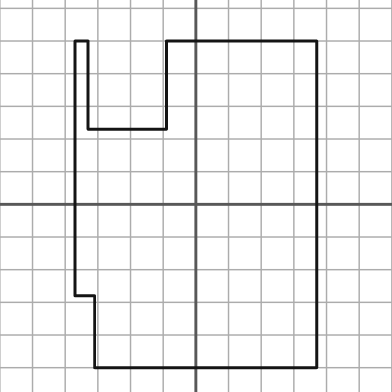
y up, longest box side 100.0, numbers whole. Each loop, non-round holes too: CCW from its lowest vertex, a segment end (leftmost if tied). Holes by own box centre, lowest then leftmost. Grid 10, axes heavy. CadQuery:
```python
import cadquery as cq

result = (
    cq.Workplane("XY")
    .moveTo(-31.0, -50.0)
    .lineTo(37.0, -50.0)
    .lineTo(37.0, 50.0)
    .lineTo(-9.0, 50.0)
    .lineTo(-9.0, 23.0)
    .lineTo(-33.0, 23.0)
    .lineTo(-33.0, 50.0)
    .lineTo(-37.0, 50.0)
    .lineTo(-37.0, -28.0)
    .lineTo(-31.0, -28.0)
    .close()
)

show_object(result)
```